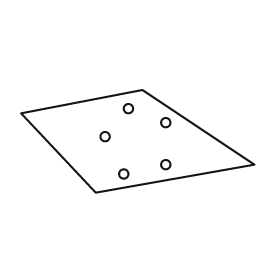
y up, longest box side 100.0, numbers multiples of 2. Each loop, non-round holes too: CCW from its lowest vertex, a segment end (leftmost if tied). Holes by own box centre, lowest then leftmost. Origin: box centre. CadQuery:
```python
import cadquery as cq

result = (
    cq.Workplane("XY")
    .moveTo(-18.0, -22.0)
    .lineTo(50.0, -10.0)
    .lineTo(2.0, 22.0)
    .lineTo(-50.0, 12.0)
    .close()
    .moveTo(-6.0, -14.0)
    .circle(2.0)
    .moveTo(12.0, -10.0)
    .circle(2.0)
    .moveTo(-14.0, 2.0)
    .circle(2.0)
    .moveTo(12.0, 8.0)
    .circle(2.0)
    .moveTo(-4.0, 14.0)
    .circle(2.0)
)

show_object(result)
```